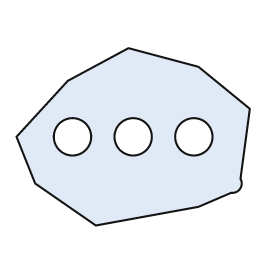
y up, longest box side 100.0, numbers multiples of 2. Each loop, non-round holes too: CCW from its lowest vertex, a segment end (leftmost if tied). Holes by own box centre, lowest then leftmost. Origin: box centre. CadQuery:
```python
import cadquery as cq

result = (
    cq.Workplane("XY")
    .moveTo(-16.0, -38.0)
    .lineTo(28.0, -30.0)
    .lineTo(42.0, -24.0)
    .threePointArc((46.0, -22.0), (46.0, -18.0))
    .lineTo(50.0, 12.0)
    .lineTo(28.0, 30.0)
    .lineTo(-2.0, 38.0)
    .lineTo(-28.0, 24.0)
    .lineTo(-50.0, 0.0)
    .lineTo(-42.0, -20.0)
    .close()
    .moveTo(-26.0, 0.0)
    .circle(8.0)
    .moveTo(0.0, 0.0)
    .circle(8.0)
    .moveTo(26.0, 0.0)
    .circle(8.0)
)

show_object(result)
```